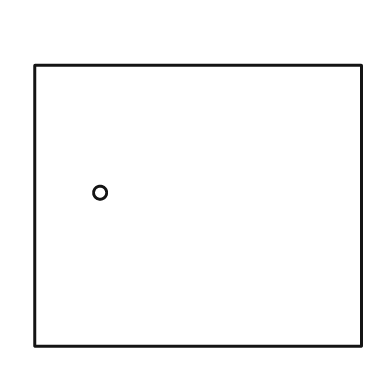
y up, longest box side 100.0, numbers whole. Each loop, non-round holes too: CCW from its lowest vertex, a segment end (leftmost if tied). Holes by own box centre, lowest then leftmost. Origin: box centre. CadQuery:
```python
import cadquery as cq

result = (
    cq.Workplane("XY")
    .moveTo(-50.0, -43.0)
    .lineTo(50.0, -43.0)
    .lineTo(50.0, 43.0)
    .lineTo(-50.0, 43.0)
    .close()
    .moveTo(-30.0, 4.0)
    .circle(2.0)
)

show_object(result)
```